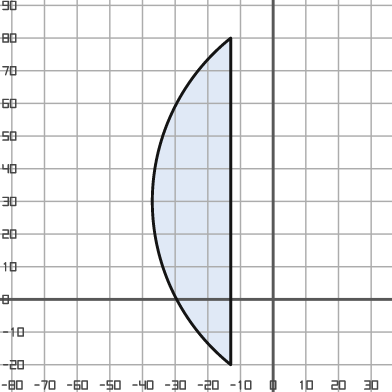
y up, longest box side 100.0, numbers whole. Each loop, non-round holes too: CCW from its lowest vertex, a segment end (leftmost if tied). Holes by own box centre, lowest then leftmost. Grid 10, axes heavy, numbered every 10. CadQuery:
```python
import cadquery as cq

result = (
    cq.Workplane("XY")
    .moveTo(-13.0, -20.0)
    .lineTo(-13.0, 80.0)
    .threePointArc((-37.0, 30.0), (-13.0, -20.0))
    .close()
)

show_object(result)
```